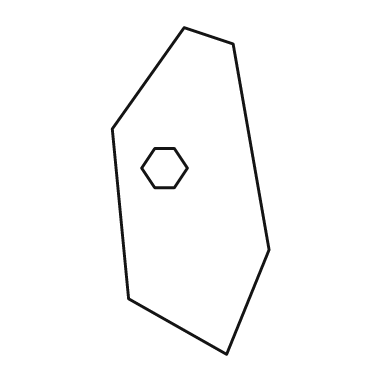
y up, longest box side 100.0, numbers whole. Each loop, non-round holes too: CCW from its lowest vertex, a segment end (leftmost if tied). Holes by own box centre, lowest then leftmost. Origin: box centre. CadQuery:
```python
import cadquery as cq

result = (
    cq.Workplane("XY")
    .moveTo(11.0, -50.0)
    .lineTo(24.0, -18.0)
    .lineTo(13.0, 45.0)
    .lineTo(-2.0, 50.0)
    .lineTo(-24.0, 19.0)
    .lineTo(-19.0, -33.0)
    .close()
    .moveTo(-11.0, 1.0)
    .lineTo(-5.0, 1.0)
    .lineTo(-1.0, 7.0)
    .lineTo(-5.0, 13.0)
    .lineTo(-11.0, 13.0)
    .lineTo(-15.0, 7.0)
    .close()
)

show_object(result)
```